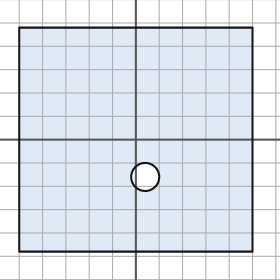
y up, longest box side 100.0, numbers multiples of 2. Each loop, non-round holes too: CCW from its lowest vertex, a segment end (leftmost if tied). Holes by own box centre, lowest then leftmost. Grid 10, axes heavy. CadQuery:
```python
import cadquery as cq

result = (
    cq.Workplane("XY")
    .moveTo(-50.0, -48.0)
    .lineTo(50.0, -48.0)
    .lineTo(50.0, 48.0)
    .lineTo(-50.0, 48.0)
    .close()
    .moveTo(4.0, -16.0)
    .circle(6.0)
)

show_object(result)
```